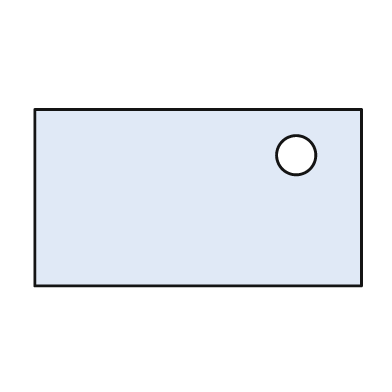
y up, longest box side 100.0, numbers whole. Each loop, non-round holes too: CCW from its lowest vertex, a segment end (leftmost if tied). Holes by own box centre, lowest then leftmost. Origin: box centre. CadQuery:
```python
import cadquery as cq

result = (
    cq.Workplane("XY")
    .moveTo(-50.0, -27.0)
    .lineTo(50.0, -27.0)
    .lineTo(50.0, 27.0)
    .lineTo(-50.0, 27.0)
    .close()
    .moveTo(30.0, 13.0)
    .circle(6.0)
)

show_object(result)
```